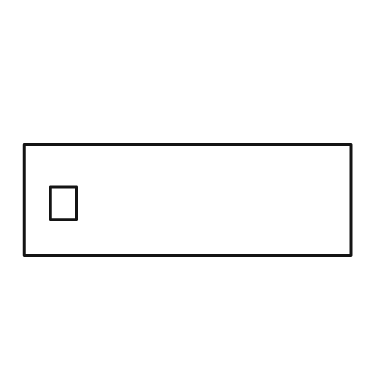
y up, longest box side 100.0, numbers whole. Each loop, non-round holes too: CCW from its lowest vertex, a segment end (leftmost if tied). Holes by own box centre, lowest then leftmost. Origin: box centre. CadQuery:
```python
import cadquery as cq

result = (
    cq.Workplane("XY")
    .moveTo(-50.0, -17.0)
    .lineTo(50.0, -17.0)
    .lineTo(50.0, 17.0)
    .lineTo(-50.0, 17.0)
    .close()
    .moveTo(-42.0, -6.0)
    .lineTo(-34.0, -6.0)
    .lineTo(-34.0, 4.0)
    .lineTo(-42.0, 4.0)
    .close()
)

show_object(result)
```